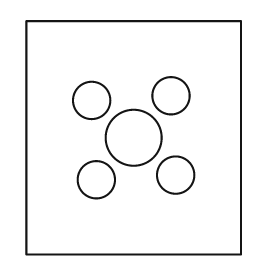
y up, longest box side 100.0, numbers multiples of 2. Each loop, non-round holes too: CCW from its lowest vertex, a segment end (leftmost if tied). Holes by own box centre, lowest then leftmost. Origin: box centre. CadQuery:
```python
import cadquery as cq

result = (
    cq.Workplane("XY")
    .moveTo(-46.0, -50.0)
    .lineTo(46.0, -50.0)
    .lineTo(46.0, 50.0)
    .lineTo(-46.0, 50.0)
    .close()
    .moveTo(-16.0, -18.0)
    .circle(8.0)
    .moveTo(18.0, -16.0)
    .circle(8.0)
    .moveTo(0.0, 0.0)
    .circle(12.0)
    .moveTo(-18.0, 16.0)
    .circle(8.0)
    .moveTo(16.0, 18.0)
    .circle(8.0)
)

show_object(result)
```